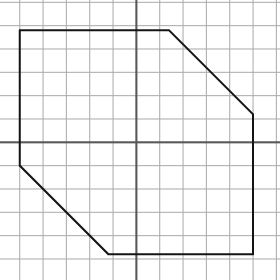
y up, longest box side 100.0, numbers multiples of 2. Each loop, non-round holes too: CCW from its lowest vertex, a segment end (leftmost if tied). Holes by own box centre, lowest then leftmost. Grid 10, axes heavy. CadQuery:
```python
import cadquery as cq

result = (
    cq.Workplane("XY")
    .moveTo(-12.0, -48.0)
    .lineTo(50.0, -48.0)
    .lineTo(50.0, 12.0)
    .lineTo(14.0, 48.0)
    .lineTo(-50.0, 48.0)
    .lineTo(-50.0, -10.0)
    .close()
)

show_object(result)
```